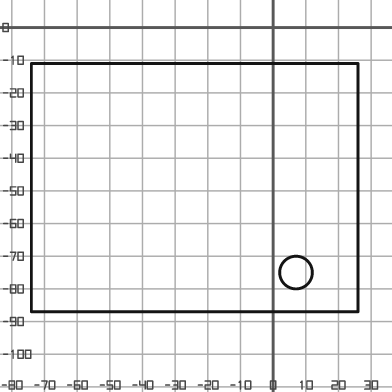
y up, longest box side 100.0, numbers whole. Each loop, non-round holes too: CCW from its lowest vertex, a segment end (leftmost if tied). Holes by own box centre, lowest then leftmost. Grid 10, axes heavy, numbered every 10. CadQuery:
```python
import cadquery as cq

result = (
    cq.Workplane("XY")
    .moveTo(-74.0, -87.0)
    .lineTo(26.0, -87.0)
    .lineTo(26.0, -11.0)
    .lineTo(-74.0, -11.0)
    .close()
    .moveTo(7.0, -75.0)
    .circle(5.0)
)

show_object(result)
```